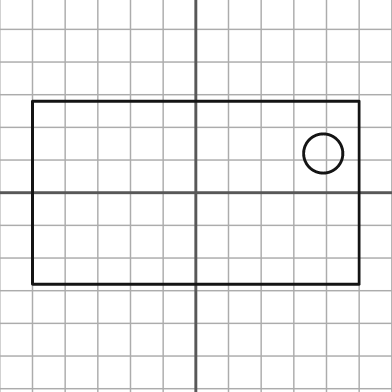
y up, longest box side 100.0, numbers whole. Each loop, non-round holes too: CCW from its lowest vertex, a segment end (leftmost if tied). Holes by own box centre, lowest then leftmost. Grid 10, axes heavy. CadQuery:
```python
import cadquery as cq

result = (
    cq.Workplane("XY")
    .moveTo(-50.0, -28.0)
    .lineTo(50.0, -28.0)
    .lineTo(50.0, 28.0)
    .lineTo(-50.0, 28.0)
    .close()
    .moveTo(39.0, 12.0)
    .circle(6.0)
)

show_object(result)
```